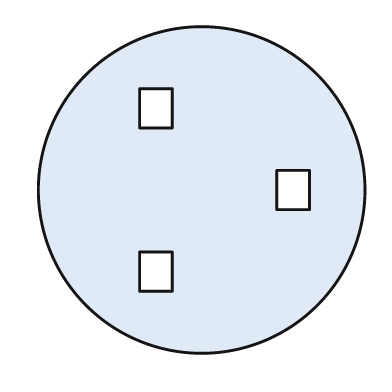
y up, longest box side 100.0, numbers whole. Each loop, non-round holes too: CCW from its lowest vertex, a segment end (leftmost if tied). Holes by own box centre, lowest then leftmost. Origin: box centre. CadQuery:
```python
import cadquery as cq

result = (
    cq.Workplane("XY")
    .moveTo(0.0, 0.0)
    .circle(50.0)
    .moveTo(-19.0, -31.0)
    .lineTo(-9.0, -31.0)
    .lineTo(-9.0, -19.0)
    .lineTo(-19.0, -19.0)
    .close()
    .moveTo(23.0, -6.0)
    .lineTo(33.0, -6.0)
    .lineTo(33.0, 6.0)
    .lineTo(23.0, 6.0)
    .close()
    .moveTo(-19.0, 19.0)
    .lineTo(-9.0, 19.0)
    .lineTo(-9.0, 31.0)
    .lineTo(-19.0, 31.0)
    .close()
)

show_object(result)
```